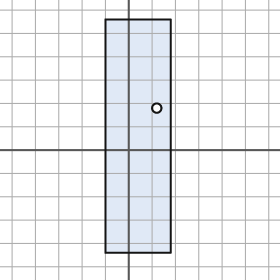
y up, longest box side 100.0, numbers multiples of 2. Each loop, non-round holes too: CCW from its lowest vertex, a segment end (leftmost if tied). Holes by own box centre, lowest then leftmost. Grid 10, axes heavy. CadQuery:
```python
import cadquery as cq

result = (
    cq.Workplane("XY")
    .moveTo(-10.0, -44.0)
    .lineTo(18.0, -44.0)
    .lineTo(18.0, 56.0)
    .lineTo(-10.0, 56.0)
    .close()
    .moveTo(12.0, 18.0)
    .circle(2.0)
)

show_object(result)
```